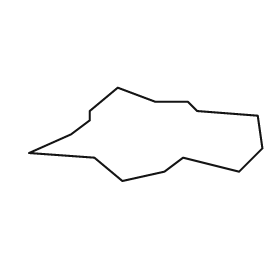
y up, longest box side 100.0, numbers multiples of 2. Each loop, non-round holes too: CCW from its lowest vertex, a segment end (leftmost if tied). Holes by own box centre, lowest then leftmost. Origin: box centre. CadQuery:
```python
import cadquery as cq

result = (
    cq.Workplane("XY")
    .moveTo(-10.0, -20.0)
    .lineTo(8.0, -16.0)
    .lineTo(16.0, -10.0)
    .lineTo(40.0, -16.0)
    .lineTo(50.0, -6.0)
    .lineTo(48.0, 8.0)
    .lineTo(22.0, 10.0)
    .lineTo(18.0, 14.0)
    .lineTo(4.0, 14.0)
    .lineTo(-12.0, 20.0)
    .lineTo(-24.0, 10.0)
    .lineTo(-24.0, 6.0)
    .lineTo(-32.0, 0.0)
    .lineTo(-50.0, -8.0)
    .lineTo(-22.0, -10.0)
    .close()
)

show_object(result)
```